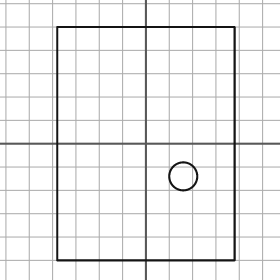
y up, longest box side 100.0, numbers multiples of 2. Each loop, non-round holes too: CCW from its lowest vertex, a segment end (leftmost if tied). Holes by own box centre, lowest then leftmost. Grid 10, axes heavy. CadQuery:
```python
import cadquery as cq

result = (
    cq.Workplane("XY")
    .moveTo(-38.0, -50.0)
    .lineTo(38.0, -50.0)
    .lineTo(38.0, 50.0)
    .lineTo(-38.0, 50.0)
    .close()
    .moveTo(16.0, -14.0)
    .circle(6.0)
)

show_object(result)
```